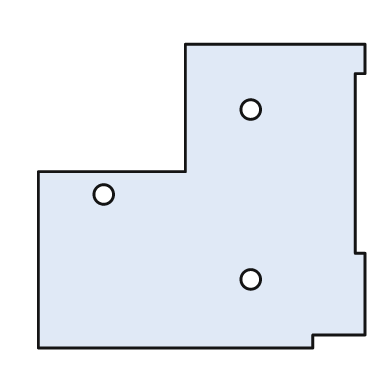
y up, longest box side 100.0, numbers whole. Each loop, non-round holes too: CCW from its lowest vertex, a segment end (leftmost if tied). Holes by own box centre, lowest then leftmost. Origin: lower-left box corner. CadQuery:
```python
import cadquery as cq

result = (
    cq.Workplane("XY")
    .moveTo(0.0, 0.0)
    .lineTo(84.0, 0.0)
    .lineTo(84.0, 4.0)
    .lineTo(100.0, 4.0)
    .lineTo(100.0, 29.0)
    .lineTo(97.0, 29.0)
    .lineTo(97.0, 84.0)
    .lineTo(100.0, 84.0)
    .lineTo(100.0, 93.0)
    .lineTo(45.0, 93.0)
    .lineTo(45.0, 54.0)
    .lineTo(0.0, 54.0)
    .close()
    .moveTo(65.0, 21.0)
    .circle(3.0)
    .moveTo(20.0, 47.0)
    .circle(3.0)
    .moveTo(65.0, 73.0)
    .circle(3.0)
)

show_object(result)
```